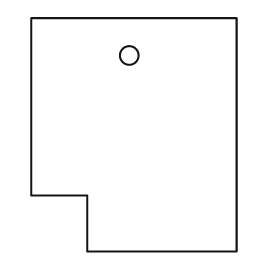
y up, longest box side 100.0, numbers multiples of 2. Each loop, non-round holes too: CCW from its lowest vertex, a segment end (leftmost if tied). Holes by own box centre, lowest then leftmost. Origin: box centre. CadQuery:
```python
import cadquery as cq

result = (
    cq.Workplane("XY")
    .moveTo(-20.0, -50.0)
    .lineTo(44.0, -50.0)
    .lineTo(44.0, 50.0)
    .lineTo(-44.0, 50.0)
    .lineTo(-44.0, -26.0)
    .lineTo(-20.0, -26.0)
    .close()
    .moveTo(-2.0, 34.0)
    .circle(4.0)
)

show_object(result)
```